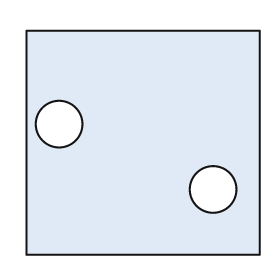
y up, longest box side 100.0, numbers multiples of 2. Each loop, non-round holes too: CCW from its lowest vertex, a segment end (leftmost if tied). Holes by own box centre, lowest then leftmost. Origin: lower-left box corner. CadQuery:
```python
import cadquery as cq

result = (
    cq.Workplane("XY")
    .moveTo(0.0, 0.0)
    .lineTo(100.0, 0.0)
    .lineTo(100.0, 96.0)
    .lineTo(0.0, 96.0)
    .close()
    .moveTo(80.0, 28.0)
    .circle(10.0)
    .moveTo(14.0, 56.0)
    .circle(10.0)
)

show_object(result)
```